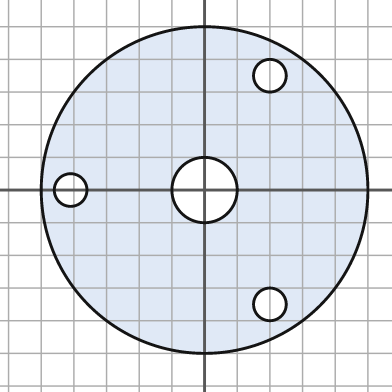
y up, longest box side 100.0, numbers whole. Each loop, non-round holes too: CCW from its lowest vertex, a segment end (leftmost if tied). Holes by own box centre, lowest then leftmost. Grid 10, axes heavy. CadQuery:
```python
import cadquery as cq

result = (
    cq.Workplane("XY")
    .moveTo(0.0, 0.0)
    .circle(50.0)
    .moveTo(20.0, -35.0)
    .circle(5.0)
    .moveTo(-41.0, 0.0)
    .circle(5.0)
    .moveTo(0.0, 0.0)
    .circle(10.0)
    .moveTo(20.0, 35.0)
    .circle(5.0)
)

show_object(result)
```